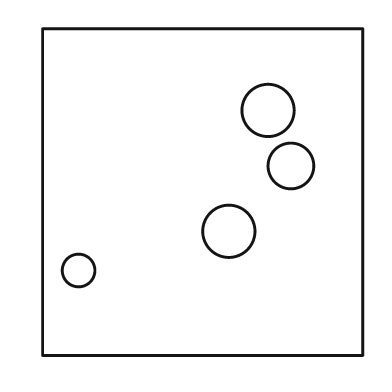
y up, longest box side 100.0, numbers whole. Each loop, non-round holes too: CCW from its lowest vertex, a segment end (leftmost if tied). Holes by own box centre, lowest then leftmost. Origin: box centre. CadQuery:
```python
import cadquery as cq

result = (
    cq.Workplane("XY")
    .moveTo(-49.0, -50.0)
    .lineTo(49.0, -50.0)
    .lineTo(49.0, 50.0)
    .lineTo(-49.0, 50.0)
    .close()
    .moveTo(-38.0, -24.0)
    .circle(5.0)
    .moveTo(8.0, -12.0)
    .circle(8.0)
    .moveTo(27.0, 8.0)
    .circle(7.0)
    .moveTo(20.0, 25.0)
    .circle(8.0)
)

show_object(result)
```